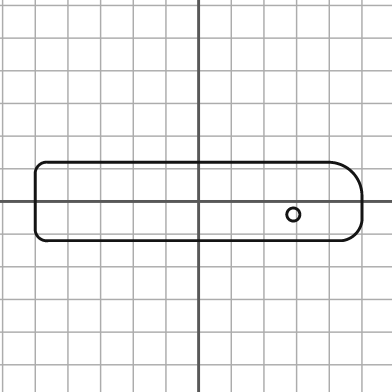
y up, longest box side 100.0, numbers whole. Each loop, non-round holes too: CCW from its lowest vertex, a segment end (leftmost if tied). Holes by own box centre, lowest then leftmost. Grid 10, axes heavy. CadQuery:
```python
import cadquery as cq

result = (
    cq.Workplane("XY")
    .moveTo(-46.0, -12.0)
    .lineTo(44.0, -12.0)
    .threePointArc((48.0, -10.0), (50.0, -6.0))
    .lineTo(50.0, 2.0)
    .threePointArc((47.0, 9.0), (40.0, 12.0))
    .lineTo(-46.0, 12.0)
    .threePointArc((-49.0, 11.0), (-50.0, 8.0))
    .lineTo(-50.0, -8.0)
    .threePointArc((-49.0, -11.0), (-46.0, -12.0))
    .close()
    .moveTo(29.0, -4.0)
    .circle(2.0)
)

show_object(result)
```